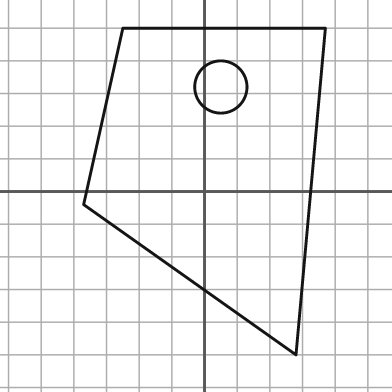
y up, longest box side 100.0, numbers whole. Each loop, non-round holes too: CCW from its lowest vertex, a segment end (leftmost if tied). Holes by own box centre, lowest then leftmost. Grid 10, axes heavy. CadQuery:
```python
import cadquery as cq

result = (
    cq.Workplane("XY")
    .moveTo(28.0, -50.0)
    .lineTo(37.0, 50.0)
    .lineTo(-25.0, 50.0)
    .lineTo(-37.0, -4.0)
    .close()
    .moveTo(5.0, 32.0)
    .circle(8.0)
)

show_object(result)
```